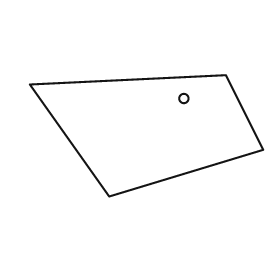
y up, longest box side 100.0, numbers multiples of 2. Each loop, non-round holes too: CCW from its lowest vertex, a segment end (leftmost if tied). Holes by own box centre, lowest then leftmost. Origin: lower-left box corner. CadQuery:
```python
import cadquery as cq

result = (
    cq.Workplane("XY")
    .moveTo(34.0, 0.0)
    .lineTo(100.0, 20.0)
    .lineTo(84.0, 52.0)
    .lineTo(0.0, 48.0)
    .close()
    .moveTo(66.0, 42.0)
    .circle(2.0)
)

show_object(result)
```